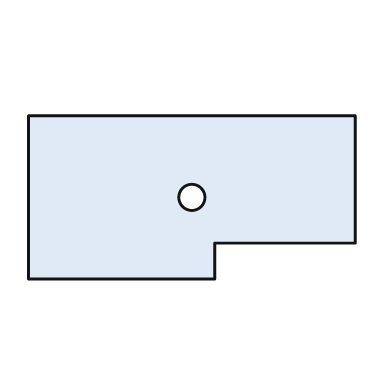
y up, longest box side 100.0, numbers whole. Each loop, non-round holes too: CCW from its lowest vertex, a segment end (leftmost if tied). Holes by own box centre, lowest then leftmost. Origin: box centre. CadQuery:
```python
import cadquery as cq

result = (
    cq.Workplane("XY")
    .moveTo(-50.0, -25.0)
    .lineTo(7.0, -25.0)
    .lineTo(7.0, -14.0)
    .lineTo(50.0, -14.0)
    .lineTo(50.0, 25.0)
    .lineTo(-50.0, 25.0)
    .close()
    .moveTo(0.0, 0.0)
    .circle(4.0)
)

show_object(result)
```